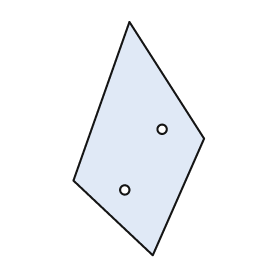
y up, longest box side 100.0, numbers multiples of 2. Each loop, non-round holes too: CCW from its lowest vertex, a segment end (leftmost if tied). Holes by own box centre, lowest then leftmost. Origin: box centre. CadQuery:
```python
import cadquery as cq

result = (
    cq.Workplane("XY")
    .moveTo(6.0, -50.0)
    .lineTo(28.0, 0.0)
    .lineTo(-4.0, 50.0)
    .lineTo(-28.0, -18.0)
    .close()
    .moveTo(-6.0, -22.0)
    .circle(2.0)
    .moveTo(10.0, 4.0)
    .circle(2.0)
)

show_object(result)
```